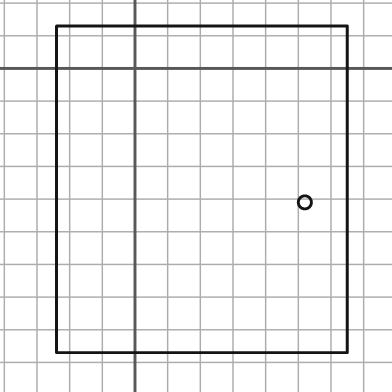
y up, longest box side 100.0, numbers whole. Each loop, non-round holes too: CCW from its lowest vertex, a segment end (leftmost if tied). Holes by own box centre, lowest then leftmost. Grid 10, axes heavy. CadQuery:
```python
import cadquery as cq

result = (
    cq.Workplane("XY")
    .moveTo(-24.0, -87.0)
    .lineTo(65.0, -87.0)
    .lineTo(65.0, 13.0)
    .lineTo(-24.0, 13.0)
    .close()
    .moveTo(52.0, -41.0)
    .circle(2.0)
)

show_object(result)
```